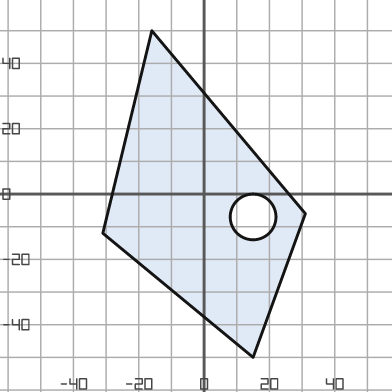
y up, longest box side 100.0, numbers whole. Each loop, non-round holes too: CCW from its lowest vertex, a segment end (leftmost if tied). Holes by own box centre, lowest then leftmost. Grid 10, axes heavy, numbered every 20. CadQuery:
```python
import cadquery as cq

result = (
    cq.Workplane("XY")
    .moveTo(15.0, -50.0)
    .lineTo(31.0, -6.0)
    .lineTo(-16.0, 50.0)
    .lineTo(-31.0, -12.0)
    .close()
    .moveTo(15.0, -7.0)
    .circle(7.0)
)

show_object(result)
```